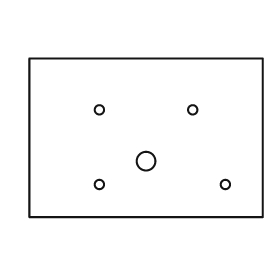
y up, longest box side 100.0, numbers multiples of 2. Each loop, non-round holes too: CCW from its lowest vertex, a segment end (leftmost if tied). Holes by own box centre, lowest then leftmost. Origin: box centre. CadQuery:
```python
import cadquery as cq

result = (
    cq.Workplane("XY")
    .moveTo(-50.0, -34.0)
    .lineTo(50.0, -34.0)
    .lineTo(50.0, 34.0)
    .lineTo(-50.0, 34.0)
    .close()
    .moveTo(-20.0, -20.0)
    .circle(2.0)
    .moveTo(34.0, -20.0)
    .circle(2.0)
    .moveTo(0.0, -10.0)
    .circle(4.0)
    .moveTo(-20.0, 12.0)
    .circle(2.0)
    .moveTo(20.0, 12.0)
    .circle(2.0)
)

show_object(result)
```